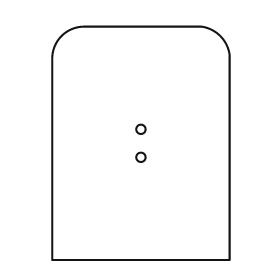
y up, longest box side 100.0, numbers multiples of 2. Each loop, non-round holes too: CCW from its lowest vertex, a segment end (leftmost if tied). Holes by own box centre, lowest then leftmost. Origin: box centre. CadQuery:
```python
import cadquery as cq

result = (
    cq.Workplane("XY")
    .moveTo(-38.0, -50.0)
    .lineTo(38.0, -50.0)
    .lineTo(38.0, 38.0)
    .threePointArc((34.0, 46.0), (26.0, 50.0))
    .lineTo(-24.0, 50.0)
    .threePointArc((-34.0, 46.0), (-38.0, 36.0))
    .close()
    .moveTo(0.0, -6.0)
    .circle(2.0)
    .moveTo(0.0, 6.0)
    .circle(2.0)
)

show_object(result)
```